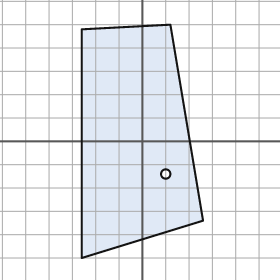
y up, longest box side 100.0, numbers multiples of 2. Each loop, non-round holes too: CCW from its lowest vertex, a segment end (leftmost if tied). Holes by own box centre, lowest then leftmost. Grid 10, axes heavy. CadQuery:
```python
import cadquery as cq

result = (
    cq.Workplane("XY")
    .moveTo(-26.0, -50.0)
    .lineTo(26.0, -34.0)
    .lineTo(12.0, 50.0)
    .lineTo(-26.0, 48.0)
    .close()
    .moveTo(10.0, -14.0)
    .circle(2.0)
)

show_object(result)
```